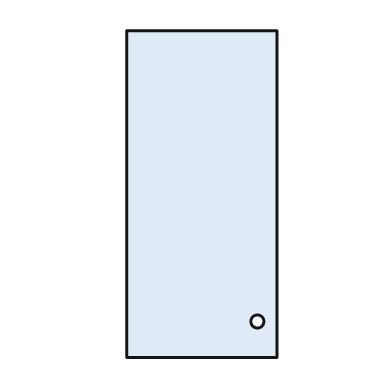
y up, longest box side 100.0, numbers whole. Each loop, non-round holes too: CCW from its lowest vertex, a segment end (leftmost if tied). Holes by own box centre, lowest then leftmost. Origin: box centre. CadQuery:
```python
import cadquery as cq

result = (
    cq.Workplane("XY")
    .moveTo(-23.0, -50.0)
    .lineTo(23.0, -50.0)
    .lineTo(23.0, 50.0)
    .lineTo(-23.0, 50.0)
    .close()
    .moveTo(17.0, -39.0)
    .circle(2.0)
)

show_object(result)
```